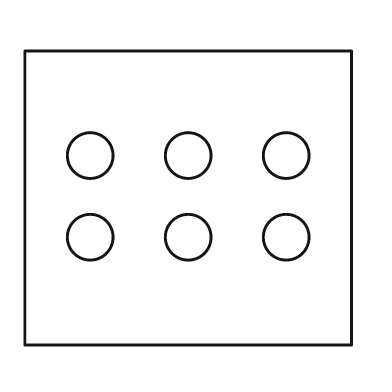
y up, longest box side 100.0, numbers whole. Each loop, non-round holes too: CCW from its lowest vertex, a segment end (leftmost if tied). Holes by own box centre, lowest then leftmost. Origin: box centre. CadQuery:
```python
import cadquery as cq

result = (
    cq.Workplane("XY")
    .moveTo(-50.0, -45.0)
    .lineTo(50.0, -45.0)
    .lineTo(50.0, 45.0)
    .lineTo(-50.0, 45.0)
    .close()
    .moveTo(-30.0, -12.0)
    .circle(7.0)
    .moveTo(0.0, -12.0)
    .circle(7.0)
    .moveTo(30.0, -12.0)
    .circle(7.0)
    .moveTo(-30.0, 13.0)
    .circle(7.0)
    .moveTo(0.0, 13.0)
    .circle(7.0)
    .moveTo(30.0, 13.0)
    .circle(7.0)
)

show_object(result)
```